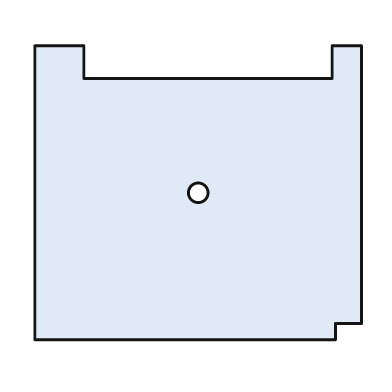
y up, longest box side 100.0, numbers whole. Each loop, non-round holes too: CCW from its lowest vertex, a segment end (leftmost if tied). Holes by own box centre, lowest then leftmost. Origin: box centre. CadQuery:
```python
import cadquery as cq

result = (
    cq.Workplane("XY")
    .moveTo(-50.0, -45.0)
    .lineTo(42.0, -45.0)
    .lineTo(42.0, -40.0)
    .lineTo(50.0, -40.0)
    .lineTo(50.0, 45.0)
    .lineTo(41.0, 45.0)
    .lineTo(41.0, 35.0)
    .lineTo(-35.0, 35.0)
    .lineTo(-35.0, 45.0)
    .lineTo(-50.0, 45.0)
    .close()
    .moveTo(0.0, 0.0)
    .circle(3.0)
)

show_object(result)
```